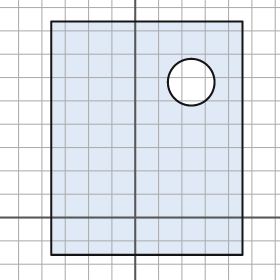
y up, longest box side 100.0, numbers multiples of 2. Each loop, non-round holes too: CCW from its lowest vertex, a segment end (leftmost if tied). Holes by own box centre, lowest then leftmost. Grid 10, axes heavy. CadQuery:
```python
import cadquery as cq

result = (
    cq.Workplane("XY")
    .moveTo(-36.0, -16.0)
    .lineTo(46.0, -16.0)
    .lineTo(46.0, 84.0)
    .lineTo(-36.0, 84.0)
    .close()
    .moveTo(24.0, 58.0)
    .circle(10.0)
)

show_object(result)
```